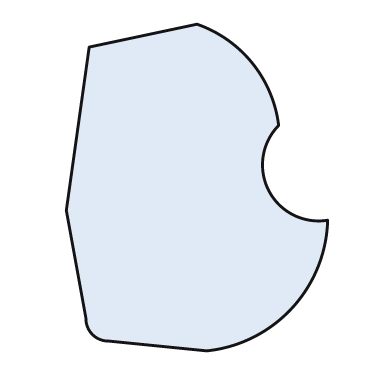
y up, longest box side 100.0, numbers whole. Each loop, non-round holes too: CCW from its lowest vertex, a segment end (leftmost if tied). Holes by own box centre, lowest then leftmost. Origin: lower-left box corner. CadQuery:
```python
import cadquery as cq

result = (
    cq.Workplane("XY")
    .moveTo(43.0, 0.0)
    .threePointArc((69.0, 13.0), (80.0, 40.0))
    .threePointArc((62.0, 49.0), (65.0, 69.0))
    .threePointArc((57.0, 88.0), (40.0, 100.0))
    .lineTo(7.0, 93.0)
    .lineTo(0.0, 43.0)
    .lineTo(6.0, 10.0)
    .threePointArc((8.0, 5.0), (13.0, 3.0))
    .close()
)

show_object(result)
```